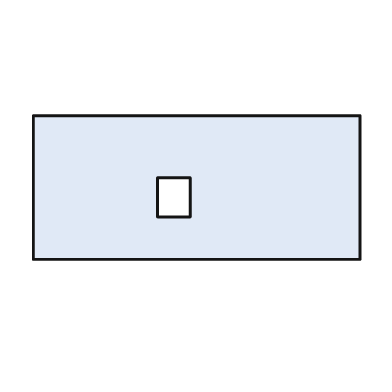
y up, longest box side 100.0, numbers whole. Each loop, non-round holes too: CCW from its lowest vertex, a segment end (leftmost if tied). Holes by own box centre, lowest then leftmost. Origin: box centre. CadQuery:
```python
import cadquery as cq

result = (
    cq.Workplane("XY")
    .moveTo(-50.0, -22.0)
    .lineTo(50.0, -22.0)
    .lineTo(50.0, 22.0)
    .lineTo(-50.0, 22.0)
    .close()
    .moveTo(-12.0, -9.0)
    .lineTo(-2.0, -9.0)
    .lineTo(-2.0, 3.0)
    .lineTo(-12.0, 3.0)
    .close()
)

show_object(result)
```